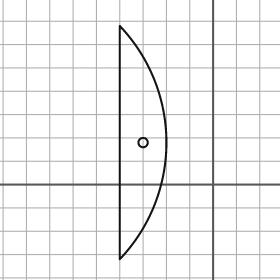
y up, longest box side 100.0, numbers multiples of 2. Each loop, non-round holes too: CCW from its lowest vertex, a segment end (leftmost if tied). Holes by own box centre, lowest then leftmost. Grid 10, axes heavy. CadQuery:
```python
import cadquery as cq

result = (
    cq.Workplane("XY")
    .moveTo(-40.0, -32.0)
    .threePointArc((-20.0, 18.0), (-40.0, 68.0))
    .close()
    .moveTo(-30.0, 18.0)
    .circle(2.0)
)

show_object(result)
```